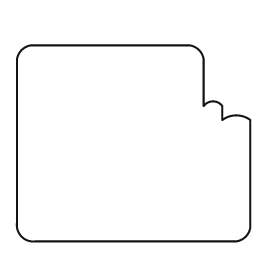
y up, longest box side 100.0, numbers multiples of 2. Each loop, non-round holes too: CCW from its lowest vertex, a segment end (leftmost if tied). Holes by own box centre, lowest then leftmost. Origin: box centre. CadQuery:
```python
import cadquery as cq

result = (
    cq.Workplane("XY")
    .moveTo(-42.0, -42.0)
    .lineTo(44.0, -42.0)
    .threePointArc((48.0, -40.0), (50.0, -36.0))
    .lineTo(50.0, 10.0)
    .threePointArc((44.0, 12.0), (38.0, 10.0))
    .lineTo(38.0, 16.0)
    .threePointArc((34.0, 18.0), (30.0, 16.0))
    .lineTo(30.0, 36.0)
    .threePointArc((28.0, 40.0), (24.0, 42.0))
    .lineTo(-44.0, 42.0)
    .threePointArc((-48.0, 40.0), (-50.0, 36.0))
    .lineTo(-50.0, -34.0)
    .threePointArc((-48.0, -40.0), (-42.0, -42.0))
    .close()
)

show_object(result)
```